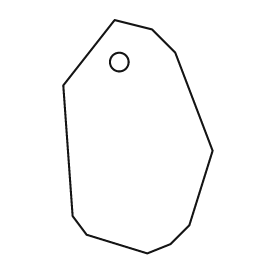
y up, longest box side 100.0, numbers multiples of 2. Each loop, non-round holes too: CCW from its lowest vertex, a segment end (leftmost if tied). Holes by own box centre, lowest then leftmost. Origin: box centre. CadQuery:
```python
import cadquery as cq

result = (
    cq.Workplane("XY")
    .moveTo(4.0, -50.0)
    .lineTo(14.0, -46.0)
    .lineTo(22.0, -38.0)
    .lineTo(32.0, -6.0)
    .lineTo(16.0, 36.0)
    .lineTo(6.0, 46.0)
    .lineTo(-10.0, 50.0)
    .lineTo(-32.0, 22.0)
    .lineTo(-28.0, -34.0)
    .lineTo(-22.0, -42.0)
    .close()
    .moveTo(-8.0, 32.0)
    .circle(4.0)
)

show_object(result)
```